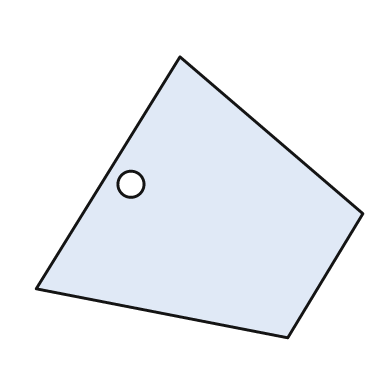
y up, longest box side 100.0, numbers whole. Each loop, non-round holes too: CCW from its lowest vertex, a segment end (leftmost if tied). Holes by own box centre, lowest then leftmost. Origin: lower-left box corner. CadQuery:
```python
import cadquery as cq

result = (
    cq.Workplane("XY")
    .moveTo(77.0, 0.0)
    .lineTo(100.0, 38.0)
    .lineTo(44.0, 86.0)
    .lineTo(0.0, 15.0)
    .close()
    .moveTo(29.0, 47.0)
    .circle(4.0)
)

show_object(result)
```